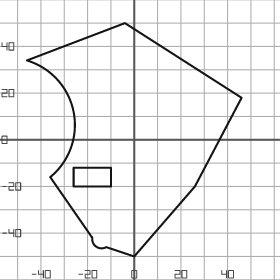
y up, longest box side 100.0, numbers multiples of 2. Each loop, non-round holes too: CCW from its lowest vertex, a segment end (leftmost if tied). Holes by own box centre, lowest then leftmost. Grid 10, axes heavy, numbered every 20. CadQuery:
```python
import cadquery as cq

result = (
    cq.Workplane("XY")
    .moveTo(0.0, -50.0)
    .lineTo(26.0, -20.0)
    .lineTo(46.0, 18.0)
    .lineTo(-4.0, 50.0)
    .lineTo(-46.0, 34.0)
    .threePointArc((-26.0, 12.0), (-36.0, -16.0))
    .lineTo(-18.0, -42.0)
    .threePointArc((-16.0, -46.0), (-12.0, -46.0))
    .close()
    .moveTo(-26.0, -20.0)
    .lineTo(-10.0, -20.0)
    .lineTo(-10.0, -12.0)
    .lineTo(-26.0, -12.0)
    .close()
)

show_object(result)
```